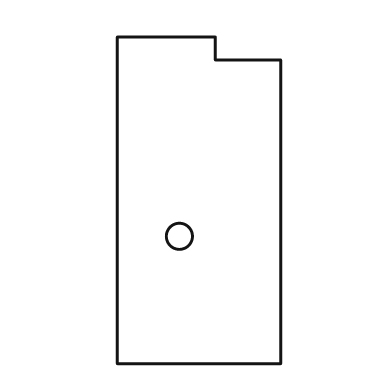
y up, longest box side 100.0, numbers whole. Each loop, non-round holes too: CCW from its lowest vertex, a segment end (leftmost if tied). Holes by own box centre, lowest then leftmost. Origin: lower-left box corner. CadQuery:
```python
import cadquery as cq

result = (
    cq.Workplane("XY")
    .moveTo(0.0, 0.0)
    .lineTo(50.0, 0.0)
    .lineTo(50.0, 93.0)
    .lineTo(30.0, 93.0)
    .lineTo(30.0, 100.0)
    .lineTo(0.0, 100.0)
    .close()
    .moveTo(19.0, 39.0)
    .circle(4.0)
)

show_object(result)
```